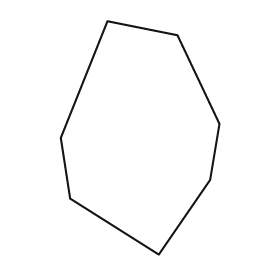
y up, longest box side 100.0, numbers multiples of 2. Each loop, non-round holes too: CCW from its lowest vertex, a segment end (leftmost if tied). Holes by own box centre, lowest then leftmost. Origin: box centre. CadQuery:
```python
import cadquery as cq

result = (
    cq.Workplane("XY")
    .moveTo(8.0, -50.0)
    .lineTo(30.0, -18.0)
    .lineTo(34.0, 6.0)
    .lineTo(16.0, 44.0)
    .lineTo(-14.0, 50.0)
    .lineTo(-34.0, 0.0)
    .lineTo(-30.0, -26.0)
    .close()
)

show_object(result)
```